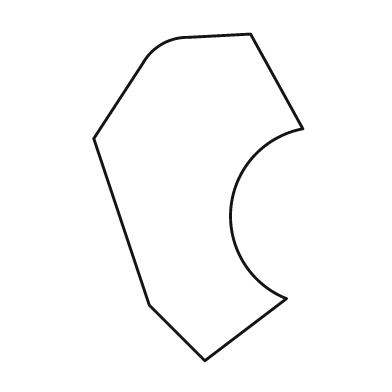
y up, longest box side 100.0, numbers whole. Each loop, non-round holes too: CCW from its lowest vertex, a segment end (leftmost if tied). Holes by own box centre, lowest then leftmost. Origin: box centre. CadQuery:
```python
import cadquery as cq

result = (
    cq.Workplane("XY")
    .moveTo(2.0, -50.0)
    .lineTo(27.0, -31.0)
    .threePointArc((10.0, -3.0), (32.0, 21.0))
    .lineTo(16.0, 50.0)
    .lineTo(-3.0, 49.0)
    .threePointArc((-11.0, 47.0), (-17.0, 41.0))
    .lineTo(-32.0, 18.0)
    .lineTo(-15.0, -33.0)
    .close()
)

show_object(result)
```